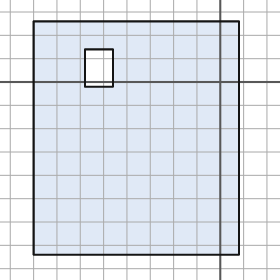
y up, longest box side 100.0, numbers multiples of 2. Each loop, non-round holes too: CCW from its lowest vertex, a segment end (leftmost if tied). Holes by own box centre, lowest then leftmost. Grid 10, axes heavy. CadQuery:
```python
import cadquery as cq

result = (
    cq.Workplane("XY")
    .moveTo(-80.0, -74.0)
    .lineTo(8.0, -74.0)
    .lineTo(8.0, 26.0)
    .lineTo(-80.0, 26.0)
    .close()
    .moveTo(-58.0, -2.0)
    .lineTo(-46.0, -2.0)
    .lineTo(-46.0, 14.0)
    .lineTo(-58.0, 14.0)
    .close()
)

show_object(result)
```